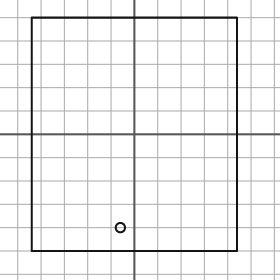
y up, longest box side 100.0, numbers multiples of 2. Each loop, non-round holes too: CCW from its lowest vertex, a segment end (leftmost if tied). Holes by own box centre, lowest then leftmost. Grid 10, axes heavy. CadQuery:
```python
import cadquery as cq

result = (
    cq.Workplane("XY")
    .moveTo(-44.0, -50.0)
    .lineTo(44.0, -50.0)
    .lineTo(44.0, 50.0)
    .lineTo(-44.0, 50.0)
    .close()
    .moveTo(-6.0, -40.0)
    .circle(2.0)
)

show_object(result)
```